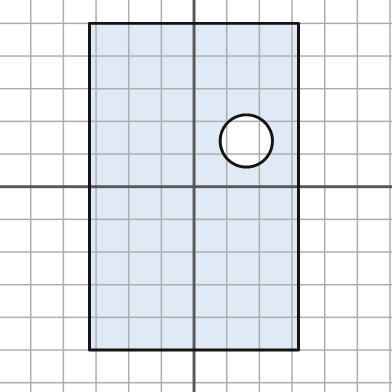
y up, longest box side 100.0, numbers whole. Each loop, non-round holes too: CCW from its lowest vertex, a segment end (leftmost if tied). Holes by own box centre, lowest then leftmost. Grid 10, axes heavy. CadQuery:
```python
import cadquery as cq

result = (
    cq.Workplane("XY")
    .moveTo(-32.0, -50.0)
    .lineTo(32.0, -50.0)
    .lineTo(32.0, 50.0)
    .lineTo(-32.0, 50.0)
    .close()
    .moveTo(16.0, 14.0)
    .circle(8.0)
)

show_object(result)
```